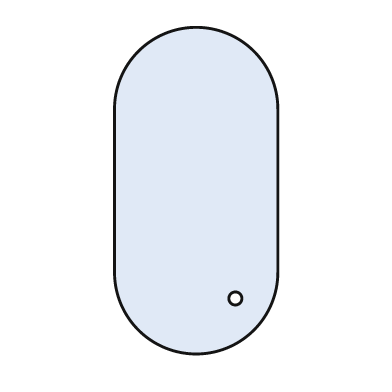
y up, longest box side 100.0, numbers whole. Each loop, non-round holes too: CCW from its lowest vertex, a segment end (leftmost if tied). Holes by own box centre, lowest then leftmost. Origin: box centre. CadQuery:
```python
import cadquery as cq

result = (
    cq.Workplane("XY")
    .moveTo(-25.0, -25.0)
    .threePointArc((0.0, -50.0), (25.0, -25.0))
    .lineTo(25.0, 25.0)
    .threePointArc((0.0, 50.0), (-25.0, 25.0))
    .close()
    .moveTo(12.0, -33.0)
    .circle(2.0)
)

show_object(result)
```